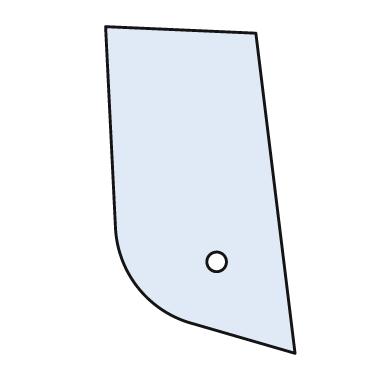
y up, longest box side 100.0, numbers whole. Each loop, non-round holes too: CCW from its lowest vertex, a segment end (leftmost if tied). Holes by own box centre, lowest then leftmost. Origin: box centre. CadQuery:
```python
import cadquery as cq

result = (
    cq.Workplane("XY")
    .moveTo(29.0, -50.0)
    .lineTo(17.0, 48.0)
    .lineTo(-29.0, 50.0)
    .lineTo(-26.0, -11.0)
    .threePointArc((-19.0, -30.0), (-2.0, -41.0))
    .close()
    .moveTo(5.0, -22.0)
    .circle(3.0)
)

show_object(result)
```